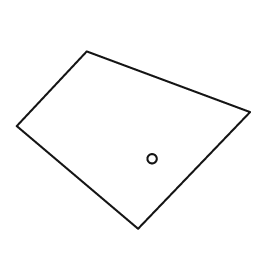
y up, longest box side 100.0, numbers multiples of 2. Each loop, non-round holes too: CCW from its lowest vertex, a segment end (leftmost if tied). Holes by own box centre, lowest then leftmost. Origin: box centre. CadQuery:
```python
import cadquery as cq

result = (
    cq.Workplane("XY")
    .moveTo(2.0, -38.0)
    .lineTo(50.0, 12.0)
    .lineTo(-20.0, 38.0)
    .lineTo(-50.0, 6.0)
    .close()
    .moveTo(8.0, -8.0)
    .circle(2.0)
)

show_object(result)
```